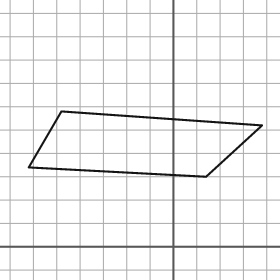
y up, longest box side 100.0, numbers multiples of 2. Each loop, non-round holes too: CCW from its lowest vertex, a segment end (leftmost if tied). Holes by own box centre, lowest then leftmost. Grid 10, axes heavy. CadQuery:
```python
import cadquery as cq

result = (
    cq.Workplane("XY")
    .moveTo(14.0, 30.0)
    .lineTo(38.0, 52.0)
    .lineTo(-48.0, 58.0)
    .lineTo(-62.0, 34.0)
    .close()
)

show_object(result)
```